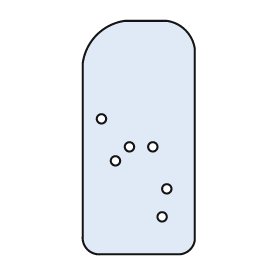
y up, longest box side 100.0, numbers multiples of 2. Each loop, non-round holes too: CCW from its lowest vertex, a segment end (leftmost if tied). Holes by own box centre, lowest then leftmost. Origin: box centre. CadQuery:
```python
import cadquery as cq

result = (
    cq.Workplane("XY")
    .moveTo(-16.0, -50.0)
    .lineTo(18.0, -50.0)
    .threePointArc((22.0, -48.0), (24.0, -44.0))
    .lineTo(24.0, 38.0)
    .threePointArc((20.0, 46.0), (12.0, 50.0))
    .lineTo(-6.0, 50.0)
    .threePointArc((-18.0, 44.0), (-24.0, 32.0))
    .lineTo(-24.0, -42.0)
    .threePointArc((-22.0, -48.0), (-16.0, -50.0))
    .close()
    .moveTo(10.0, -34.0)
    .circle(2.0)
    .moveTo(12.0, -22.0)
    .circle(2.0)
    .moveTo(-10.0, -10.0)
    .circle(2.0)
    .moveTo(-4.0, -4.0)
    .circle(2.0)
    .moveTo(6.0, -4.0)
    .circle(2.0)
    .moveTo(-16.0, 8.0)
    .circle(2.0)
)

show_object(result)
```